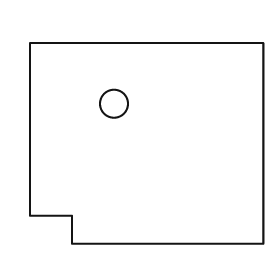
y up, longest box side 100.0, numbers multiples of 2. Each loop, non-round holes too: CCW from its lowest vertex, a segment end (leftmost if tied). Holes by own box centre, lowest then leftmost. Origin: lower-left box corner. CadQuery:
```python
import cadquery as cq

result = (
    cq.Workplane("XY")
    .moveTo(18.0, 0.0)
    .lineTo(100.0, 0.0)
    .lineTo(100.0, 86.0)
    .lineTo(0.0, 86.0)
    .lineTo(0.0, 12.0)
    .lineTo(18.0, 12.0)
    .close()
    .moveTo(36.0, 60.0)
    .circle(6.0)
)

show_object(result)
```